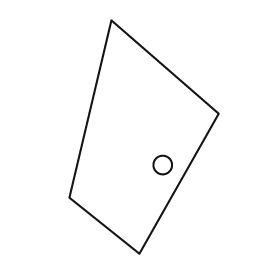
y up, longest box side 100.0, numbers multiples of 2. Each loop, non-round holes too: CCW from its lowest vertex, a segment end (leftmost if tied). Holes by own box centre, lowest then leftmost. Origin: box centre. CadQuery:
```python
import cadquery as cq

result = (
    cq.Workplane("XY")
    .moveTo(-2.0, -50.0)
    .lineTo(32.0, 10.0)
    .lineTo(-14.0, 50.0)
    .lineTo(-32.0, -26.0)
    .close()
    .moveTo(8.0, -12.0)
    .circle(4.0)
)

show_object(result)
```